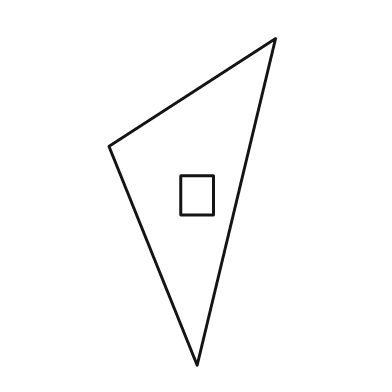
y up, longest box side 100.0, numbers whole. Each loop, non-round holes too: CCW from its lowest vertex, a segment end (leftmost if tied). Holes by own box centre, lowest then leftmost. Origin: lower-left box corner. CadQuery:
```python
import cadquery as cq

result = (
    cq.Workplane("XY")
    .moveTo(27.0, 0.0)
    .lineTo(51.0, 100.0)
    .lineTo(0.0, 67.0)
    .close()
    .moveTo(22.0, 46.0)
    .lineTo(32.0, 46.0)
    .lineTo(32.0, 58.0)
    .lineTo(22.0, 58.0)
    .close()
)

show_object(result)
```